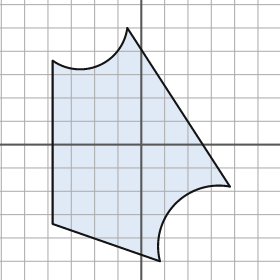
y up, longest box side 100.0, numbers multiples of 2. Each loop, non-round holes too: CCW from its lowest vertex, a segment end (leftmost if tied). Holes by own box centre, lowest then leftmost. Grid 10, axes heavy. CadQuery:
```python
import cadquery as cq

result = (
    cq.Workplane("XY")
    .moveTo(8.0, -50.0)
    .threePointArc((14.0, -26.0), (38.0, -18.0))
    .lineTo(-6.0, 50.0)
    .threePointArc((-18.0, 34.0), (-38.0, 36.0))
    .lineTo(-38.0, -34.0)
    .close()
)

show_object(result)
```